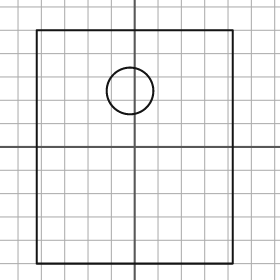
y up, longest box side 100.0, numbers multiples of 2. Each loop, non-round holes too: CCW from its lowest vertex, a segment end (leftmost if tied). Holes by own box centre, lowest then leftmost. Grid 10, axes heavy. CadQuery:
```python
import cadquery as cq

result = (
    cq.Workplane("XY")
    .moveTo(-42.0, -50.0)
    .lineTo(42.0, -50.0)
    .lineTo(42.0, 50.0)
    .lineTo(-42.0, 50.0)
    .close()
    .moveTo(-2.0, 24.0)
    .circle(10.0)
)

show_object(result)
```